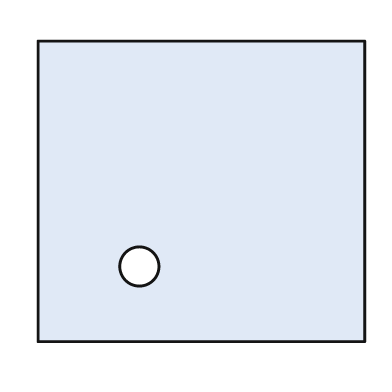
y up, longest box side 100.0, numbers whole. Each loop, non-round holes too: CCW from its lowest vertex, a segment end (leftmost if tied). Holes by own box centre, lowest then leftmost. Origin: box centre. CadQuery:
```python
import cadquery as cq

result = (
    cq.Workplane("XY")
    .moveTo(-50.0, -46.0)
    .lineTo(50.0, -46.0)
    .lineTo(50.0, 46.0)
    .lineTo(-50.0, 46.0)
    .close()
    .moveTo(-19.0, -23.0)
    .circle(6.0)
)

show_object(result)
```